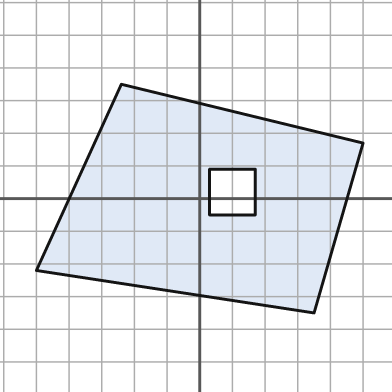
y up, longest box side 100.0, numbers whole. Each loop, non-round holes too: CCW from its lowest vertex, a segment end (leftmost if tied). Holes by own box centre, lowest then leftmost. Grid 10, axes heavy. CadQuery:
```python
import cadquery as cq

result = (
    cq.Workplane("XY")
    .moveTo(35.0, -35.0)
    .lineTo(50.0, 17.0)
    .lineTo(-24.0, 35.0)
    .lineTo(-50.0, -22.0)
    .close()
    .moveTo(3.0, -5.0)
    .lineTo(17.0, -5.0)
    .lineTo(17.0, 9.0)
    .lineTo(3.0, 9.0)
    .close()
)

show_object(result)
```